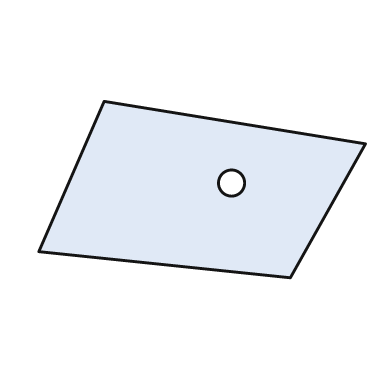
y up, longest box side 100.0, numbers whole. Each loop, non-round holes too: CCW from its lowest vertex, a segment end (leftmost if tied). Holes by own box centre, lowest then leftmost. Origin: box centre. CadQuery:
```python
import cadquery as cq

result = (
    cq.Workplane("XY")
    .moveTo(27.0, -27.0)
    .lineTo(50.0, 14.0)
    .lineTo(-30.0, 27.0)
    .lineTo(-50.0, -19.0)
    .close()
    .moveTo(9.0, 2.0)
    .circle(4.0)
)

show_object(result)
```